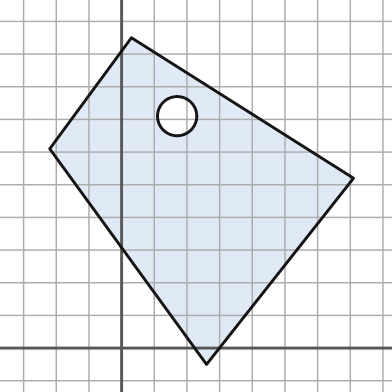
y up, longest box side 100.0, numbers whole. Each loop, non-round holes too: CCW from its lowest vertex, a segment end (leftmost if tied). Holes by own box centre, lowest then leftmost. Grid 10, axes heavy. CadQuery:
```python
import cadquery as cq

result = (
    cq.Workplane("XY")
    .moveTo(26.0, -5.0)
    .lineTo(71.0, 52.0)
    .lineTo(3.0, 95.0)
    .lineTo(-22.0, 61.0)
    .close()
    .moveTo(17.0, 71.0)
    .circle(6.0)
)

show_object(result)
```